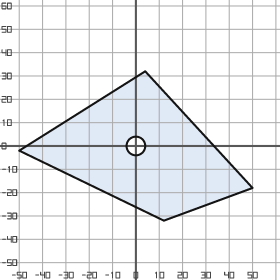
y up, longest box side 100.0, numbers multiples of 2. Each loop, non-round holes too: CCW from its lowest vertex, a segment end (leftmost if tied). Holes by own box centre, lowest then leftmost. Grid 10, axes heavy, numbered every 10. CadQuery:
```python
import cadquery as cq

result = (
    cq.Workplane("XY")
    .moveTo(12.0, -32.0)
    .lineTo(50.0, -18.0)
    .lineTo(4.0, 32.0)
    .lineTo(-50.0, -2.0)
    .close()
    .moveTo(0.0, 0.0)
    .circle(4.0)
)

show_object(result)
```